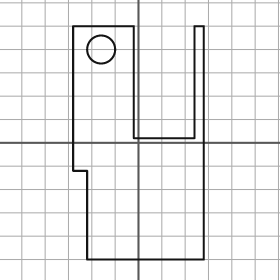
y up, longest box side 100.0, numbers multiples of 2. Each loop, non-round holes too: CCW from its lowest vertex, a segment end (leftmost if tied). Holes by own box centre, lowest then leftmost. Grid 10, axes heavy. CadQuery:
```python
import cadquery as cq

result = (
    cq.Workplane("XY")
    .moveTo(-22.0, -50.0)
    .lineTo(28.0, -50.0)
    .lineTo(28.0, 50.0)
    .lineTo(24.0, 50.0)
    .lineTo(24.0, 2.0)
    .lineTo(-2.0, 2.0)
    .lineTo(-2.0, 50.0)
    .lineTo(-28.0, 50.0)
    .lineTo(-28.0, -12.0)
    .lineTo(-22.0, -12.0)
    .close()
    .moveTo(-16.0, 40.0)
    .circle(6.0)
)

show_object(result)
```